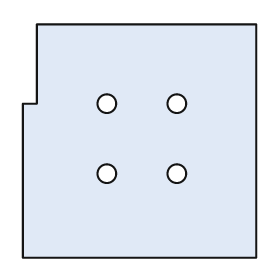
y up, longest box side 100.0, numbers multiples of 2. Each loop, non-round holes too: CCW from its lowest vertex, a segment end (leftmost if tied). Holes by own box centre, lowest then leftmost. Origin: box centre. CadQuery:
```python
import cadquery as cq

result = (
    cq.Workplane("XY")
    .moveTo(-50.0, -50.0)
    .lineTo(50.0, -50.0)
    .lineTo(50.0, 50.0)
    .lineTo(-44.0, 50.0)
    .lineTo(-44.0, 16.0)
    .lineTo(-50.0, 16.0)
    .close()
    .moveTo(-14.0, -14.0)
    .circle(4.0)
    .moveTo(16.0, -14.0)
    .circle(4.0)
    .moveTo(-14.0, 16.0)
    .circle(4.0)
    .moveTo(16.0, 16.0)
    .circle(4.0)
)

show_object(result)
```